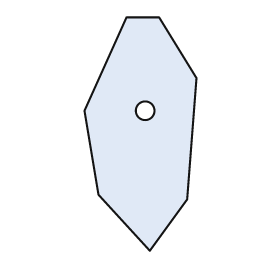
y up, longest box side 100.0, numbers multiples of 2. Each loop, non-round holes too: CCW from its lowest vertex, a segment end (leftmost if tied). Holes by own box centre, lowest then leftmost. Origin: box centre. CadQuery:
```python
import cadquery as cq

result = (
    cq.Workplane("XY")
    .moveTo(4.0, -50.0)
    .lineTo(20.0, -28.0)
    .lineTo(24.0, 24.0)
    .lineTo(8.0, 50.0)
    .lineTo(-6.0, 50.0)
    .lineTo(-24.0, 10.0)
    .lineTo(-18.0, -26.0)
    .close()
    .moveTo(2.0, 10.0)
    .circle(4.0)
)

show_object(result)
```